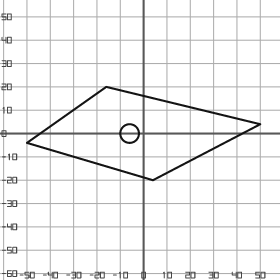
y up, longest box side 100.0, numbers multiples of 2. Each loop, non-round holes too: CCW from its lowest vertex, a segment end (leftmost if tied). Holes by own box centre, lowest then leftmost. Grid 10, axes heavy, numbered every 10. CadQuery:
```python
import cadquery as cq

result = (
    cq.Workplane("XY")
    .moveTo(4.0, -20.0)
    .lineTo(50.0, 4.0)
    .lineTo(-16.0, 20.0)
    .lineTo(-50.0, -4.0)
    .close()
    .moveTo(-6.0, 0.0)
    .circle(4.0)
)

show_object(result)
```